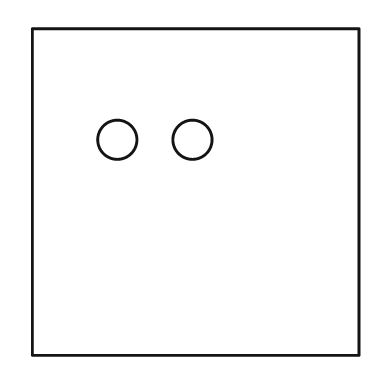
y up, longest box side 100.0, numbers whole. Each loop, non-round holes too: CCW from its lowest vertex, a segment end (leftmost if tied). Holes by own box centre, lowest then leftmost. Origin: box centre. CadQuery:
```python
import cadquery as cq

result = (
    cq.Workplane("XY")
    .moveTo(-50.0, -50.0)
    .lineTo(50.0, -50.0)
    .lineTo(50.0, 50.0)
    .lineTo(-50.0, 50.0)
    .close()
    .moveTo(-24.0, 16.0)
    .circle(6.0)
    .moveTo(-1.0, 16.0)
    .circle(6.0)
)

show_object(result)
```